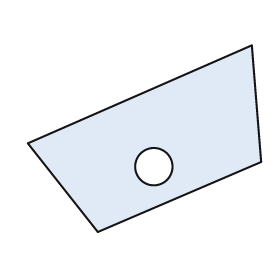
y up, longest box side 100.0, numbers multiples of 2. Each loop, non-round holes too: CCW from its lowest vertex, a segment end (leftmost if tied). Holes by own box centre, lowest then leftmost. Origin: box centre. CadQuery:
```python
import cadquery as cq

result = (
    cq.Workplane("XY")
    .moveTo(-20.0, -40.0)
    .lineTo(50.0, -10.0)
    .lineTo(46.0, 40.0)
    .lineTo(-50.0, -2.0)
    .close()
    .moveTo(4.0, -12.0)
    .circle(8.0)
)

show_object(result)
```